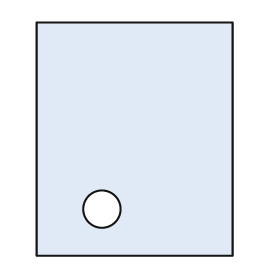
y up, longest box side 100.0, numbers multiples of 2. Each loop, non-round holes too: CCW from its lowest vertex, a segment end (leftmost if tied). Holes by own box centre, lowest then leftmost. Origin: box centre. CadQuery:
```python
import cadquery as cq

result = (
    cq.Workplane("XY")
    .moveTo(-42.0, -50.0)
    .lineTo(42.0, -50.0)
    .lineTo(42.0, 50.0)
    .lineTo(-42.0, 50.0)
    .close()
    .moveTo(-14.0, -30.0)
    .circle(8.0)
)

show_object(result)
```